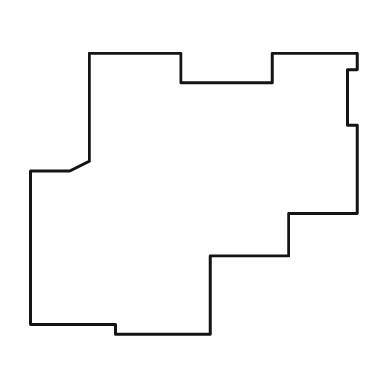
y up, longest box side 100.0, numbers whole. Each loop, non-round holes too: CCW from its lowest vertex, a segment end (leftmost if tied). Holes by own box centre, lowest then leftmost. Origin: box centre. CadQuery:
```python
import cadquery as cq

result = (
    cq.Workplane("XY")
    .moveTo(-24.0, -43.0)
    .lineTo(5.0, -43.0)
    .lineTo(5.0, -19.0)
    .lineTo(29.0, -19.0)
    .lineTo(29.0, -6.0)
    .lineTo(50.0, -6.0)
    .lineTo(50.0, 21.0)
    .lineTo(47.0, 21.0)
    .lineTo(47.0, 38.0)
    .lineTo(50.0, 38.0)
    .lineTo(50.0, 43.0)
    .lineTo(24.0, 43.0)
    .lineTo(24.0, 34.0)
    .lineTo(-4.0, 34.0)
    .lineTo(-4.0, 43.0)
    .lineTo(-32.0, 43.0)
    .lineTo(-32.0, 10.0)
    .lineTo(-38.0, 7.0)
    .lineTo(-50.0, 7.0)
    .lineTo(-50.0, -40.0)
    .lineTo(-24.0, -40.0)
    .close()
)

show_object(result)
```